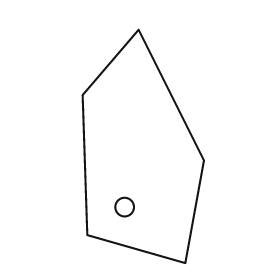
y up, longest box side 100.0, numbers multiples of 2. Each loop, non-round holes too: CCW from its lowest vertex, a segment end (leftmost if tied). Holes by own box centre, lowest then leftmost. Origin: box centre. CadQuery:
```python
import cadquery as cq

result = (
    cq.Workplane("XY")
    .moveTo(18.0, -50.0)
    .lineTo(26.0, -6.0)
    .lineTo(-2.0, 50.0)
    .lineTo(-26.0, 22.0)
    .lineTo(-24.0, -38.0)
    .close()
    .moveTo(-8.0, -26.0)
    .circle(4.0)
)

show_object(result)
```